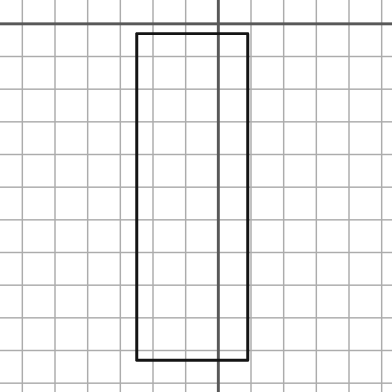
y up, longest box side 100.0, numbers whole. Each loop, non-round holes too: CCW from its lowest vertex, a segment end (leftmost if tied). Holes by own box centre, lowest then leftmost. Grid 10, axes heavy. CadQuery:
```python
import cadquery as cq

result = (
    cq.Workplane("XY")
    .moveTo(-25.0, -103.0)
    .lineTo(9.0, -103.0)
    .lineTo(9.0, -3.0)
    .lineTo(-25.0, -3.0)
    .close()
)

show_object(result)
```